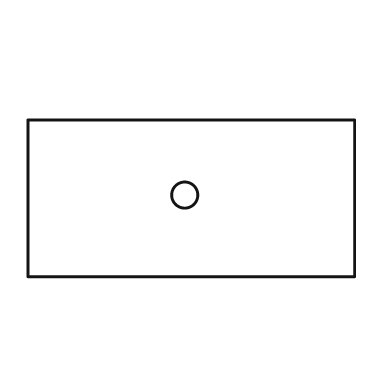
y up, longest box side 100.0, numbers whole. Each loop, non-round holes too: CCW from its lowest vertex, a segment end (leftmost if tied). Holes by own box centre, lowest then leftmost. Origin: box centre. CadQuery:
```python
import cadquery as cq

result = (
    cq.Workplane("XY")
    .moveTo(-50.0, -24.0)
    .lineTo(50.0, -24.0)
    .lineTo(50.0, 24.0)
    .lineTo(-50.0, 24.0)
    .close()
    .moveTo(-2.0, 1.0)
    .circle(4.0)
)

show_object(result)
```